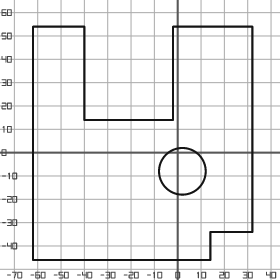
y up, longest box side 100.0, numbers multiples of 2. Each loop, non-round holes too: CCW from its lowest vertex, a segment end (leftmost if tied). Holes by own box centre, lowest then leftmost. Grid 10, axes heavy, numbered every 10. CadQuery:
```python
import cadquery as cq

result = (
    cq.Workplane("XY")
    .moveTo(-62.0, -46.0)
    .lineTo(14.0, -46.0)
    .lineTo(14.0, -34.0)
    .lineTo(32.0, -34.0)
    .lineTo(32.0, 54.0)
    .lineTo(-2.0, 54.0)
    .lineTo(-2.0, 14.0)
    .lineTo(-40.0, 14.0)
    .lineTo(-40.0, 54.0)
    .lineTo(-62.0, 54.0)
    .close()
    .moveTo(2.0, -8.0)
    .circle(10.0)
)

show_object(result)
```